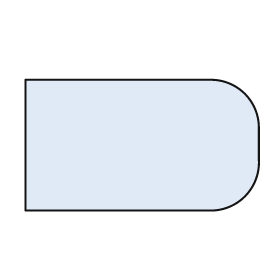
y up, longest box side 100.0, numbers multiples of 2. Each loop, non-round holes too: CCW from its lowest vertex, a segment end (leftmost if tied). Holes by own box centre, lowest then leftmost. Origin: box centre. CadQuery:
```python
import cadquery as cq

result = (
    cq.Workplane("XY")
    .moveTo(-50.0, -28.0)
    .lineTo(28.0, -28.0)
    .threePointArc((44.0, -22.0), (50.0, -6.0))
    .lineTo(50.0, 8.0)
    .threePointArc((44.0, 22.0), (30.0, 28.0))
    .lineTo(-50.0, 28.0)
    .close()
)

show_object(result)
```